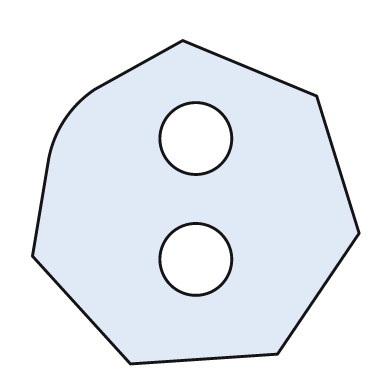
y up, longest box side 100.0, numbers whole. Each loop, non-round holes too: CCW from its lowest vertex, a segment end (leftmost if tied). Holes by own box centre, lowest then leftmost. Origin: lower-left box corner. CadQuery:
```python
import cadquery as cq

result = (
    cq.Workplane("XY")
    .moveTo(30.0, 0.0)
    .lineTo(75.0, 3.0)
    .lineTo(100.0, 40.0)
    .lineTo(87.0, 82.0)
    .lineTo(46.0, 99.0)
    .lineTo(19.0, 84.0)
    .threePointArc((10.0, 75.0), (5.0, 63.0))
    .lineTo(0.0, 33.0)
    .close()
    .moveTo(50.0, 32.0)
    .circle(11.0)
    .moveTo(50.0, 69.0)
    .circle(11.0)
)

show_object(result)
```